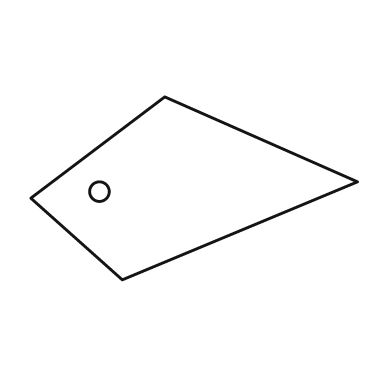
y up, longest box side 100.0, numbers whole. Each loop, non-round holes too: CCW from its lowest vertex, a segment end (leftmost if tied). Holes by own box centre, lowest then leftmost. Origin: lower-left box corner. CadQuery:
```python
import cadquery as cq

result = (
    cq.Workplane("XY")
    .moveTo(28.0, 0.0)
    .lineTo(100.0, 30.0)
    .lineTo(41.0, 56.0)
    .lineTo(0.0, 25.0)
    .close()
    .moveTo(21.0, 27.0)
    .circle(3.0)
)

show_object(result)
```